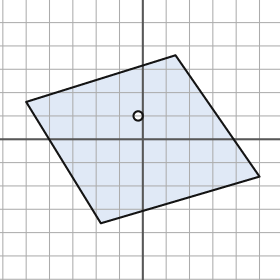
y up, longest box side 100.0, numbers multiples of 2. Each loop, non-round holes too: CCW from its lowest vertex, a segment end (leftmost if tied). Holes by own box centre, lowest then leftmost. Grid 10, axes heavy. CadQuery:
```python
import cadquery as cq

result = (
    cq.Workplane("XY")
    .moveTo(-18.0, -36.0)
    .lineTo(50.0, -16.0)
    .lineTo(14.0, 36.0)
    .lineTo(-50.0, 16.0)
    .close()
    .moveTo(-2.0, 10.0)
    .circle(2.0)
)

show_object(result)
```